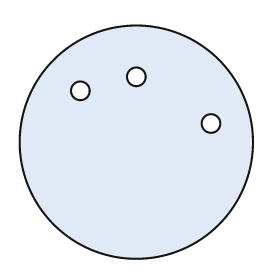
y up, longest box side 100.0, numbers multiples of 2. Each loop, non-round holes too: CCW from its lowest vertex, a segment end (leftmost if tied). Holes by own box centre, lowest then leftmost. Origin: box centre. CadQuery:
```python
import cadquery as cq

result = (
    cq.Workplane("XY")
    .moveTo(0.0, 0.0)
    .circle(50.0)
    .moveTo(32.0, 8.0)
    .circle(4.0)
    .moveTo(-24.0, 22.0)
    .circle(4.0)
    .moveTo(0.0, 28.0)
    .circle(4.0)
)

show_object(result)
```